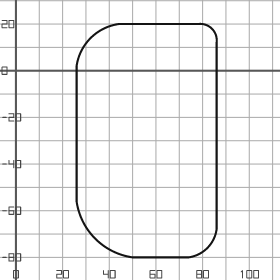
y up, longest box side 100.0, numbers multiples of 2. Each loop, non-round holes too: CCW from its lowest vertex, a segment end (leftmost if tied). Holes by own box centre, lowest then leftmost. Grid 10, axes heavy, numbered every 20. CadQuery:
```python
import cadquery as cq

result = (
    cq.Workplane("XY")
    .moveTo(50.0, -80.0)
    .lineTo(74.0, -80.0)
    .threePointArc((82.0, -76.0), (86.0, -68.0))
    .lineTo(86.0, 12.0)
    .threePointArc((84.0, 18.0), (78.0, 20.0))
    .lineTo(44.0, 20.0)
    .threePointArc((32.0, 14.0), (26.0, 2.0))
    .lineTo(26.0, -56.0)
    .threePointArc((34.0, -72.0), (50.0, -80.0))
    .close()
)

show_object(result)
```